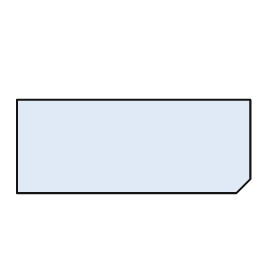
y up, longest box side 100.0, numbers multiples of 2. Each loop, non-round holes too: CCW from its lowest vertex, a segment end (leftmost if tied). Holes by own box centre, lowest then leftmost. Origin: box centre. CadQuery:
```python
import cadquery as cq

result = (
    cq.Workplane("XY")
    .moveTo(-50.0, -20.0)
    .lineTo(44.0, -20.0)
    .lineTo(50.0, -14.0)
    .lineTo(50.0, 20.0)
    .lineTo(-50.0, 20.0)
    .close()
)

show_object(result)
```